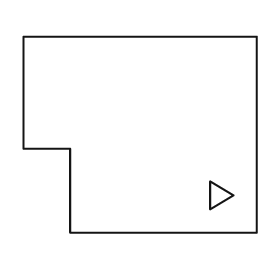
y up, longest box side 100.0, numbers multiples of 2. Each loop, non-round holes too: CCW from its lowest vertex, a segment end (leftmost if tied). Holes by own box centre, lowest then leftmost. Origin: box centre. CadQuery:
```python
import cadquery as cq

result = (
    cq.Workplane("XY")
    .moveTo(-30.0, -42.0)
    .lineTo(50.0, -42.0)
    .lineTo(50.0, 42.0)
    .lineTo(-50.0, 42.0)
    .lineTo(-50.0, -6.0)
    .lineTo(-30.0, -6.0)
    .close()
    .moveTo(30.0, -32.0)
    .lineTo(40.0, -26.0)
    .lineTo(30.0, -20.0)
    .close()
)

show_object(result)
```